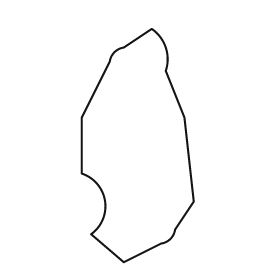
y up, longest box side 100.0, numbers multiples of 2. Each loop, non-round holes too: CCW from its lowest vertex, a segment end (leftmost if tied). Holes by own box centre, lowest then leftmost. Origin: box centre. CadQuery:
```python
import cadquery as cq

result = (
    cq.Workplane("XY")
    .moveTo(-6.0, -50.0)
    .lineTo(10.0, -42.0)
    .threePointArc((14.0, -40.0), (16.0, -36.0))
    .lineTo(24.0, -24.0)
    .lineTo(20.0, 12.0)
    .lineTo(12.0, 32.0)
    .threePointArc((12.0, 42.0), (6.0, 50.0))
    .lineTo(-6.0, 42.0)
    .threePointArc((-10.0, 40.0), (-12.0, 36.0))
    .lineTo(-24.0, 12.0)
    .lineTo(-24.0, -12.0)
    .threePointArc((-14.0, -24.0), (-20.0, -38.0))
    .close()
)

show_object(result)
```